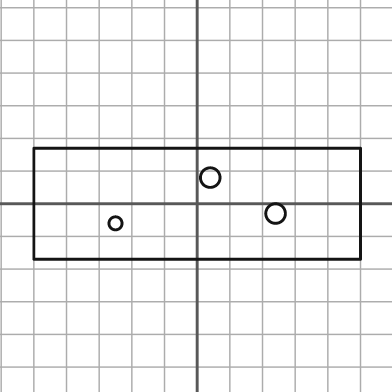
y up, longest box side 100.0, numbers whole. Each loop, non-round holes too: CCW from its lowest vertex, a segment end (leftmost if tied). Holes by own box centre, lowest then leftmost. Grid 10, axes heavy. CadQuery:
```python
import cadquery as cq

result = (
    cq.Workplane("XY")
    .moveTo(-50.0, -17.0)
    .lineTo(50.0, -17.0)
    .lineTo(50.0, 17.0)
    .lineTo(-50.0, 17.0)
    .close()
    .moveTo(-25.0, -6.0)
    .circle(2.0)
    .moveTo(24.0, -3.0)
    .circle(3.0)
    .moveTo(4.0, 8.0)
    .circle(3.0)
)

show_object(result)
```